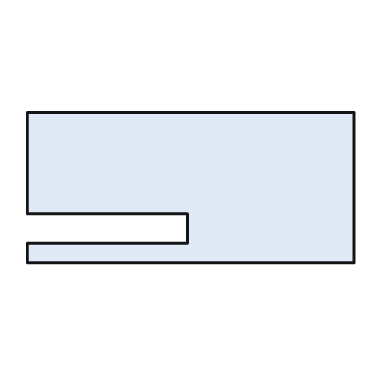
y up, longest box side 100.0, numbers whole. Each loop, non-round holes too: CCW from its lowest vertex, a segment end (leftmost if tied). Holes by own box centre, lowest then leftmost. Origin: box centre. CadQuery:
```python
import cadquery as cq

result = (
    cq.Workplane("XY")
    .moveTo(-50.0, -23.0)
    .lineTo(50.0, -23.0)
    .lineTo(50.0, 23.0)
    .lineTo(-50.0, 23.0)
    .lineTo(-50.0, -8.0)
    .lineTo(-1.0, -8.0)
    .lineTo(-1.0, -17.0)
    .lineTo(-50.0, -17.0)
    .close()
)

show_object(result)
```